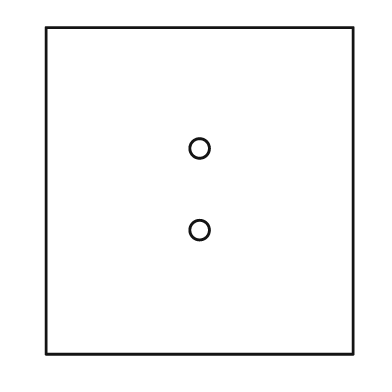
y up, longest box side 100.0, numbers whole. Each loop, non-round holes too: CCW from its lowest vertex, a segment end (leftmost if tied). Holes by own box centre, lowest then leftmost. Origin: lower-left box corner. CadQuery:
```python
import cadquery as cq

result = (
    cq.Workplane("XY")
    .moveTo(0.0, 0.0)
    .lineTo(94.0, 0.0)
    .lineTo(94.0, 100.0)
    .lineTo(0.0, 100.0)
    .close()
    .moveTo(47.0, 38.0)
    .circle(3.0)
    .moveTo(47.0, 63.0)
    .circle(3.0)
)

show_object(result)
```